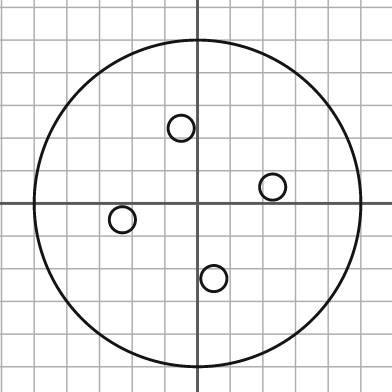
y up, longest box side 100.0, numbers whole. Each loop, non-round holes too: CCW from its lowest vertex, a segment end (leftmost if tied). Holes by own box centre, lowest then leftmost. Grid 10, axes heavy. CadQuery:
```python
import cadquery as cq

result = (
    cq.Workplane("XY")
    .moveTo(0.0, 0.0)
    .circle(50.0)
    .moveTo(5.0, -23.0)
    .circle(4.0)
    .moveTo(-23.0, -5.0)
    .circle(4.0)
    .moveTo(23.0, 5.0)
    .circle(4.0)
    .moveTo(-5.0, 23.0)
    .circle(4.0)
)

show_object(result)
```